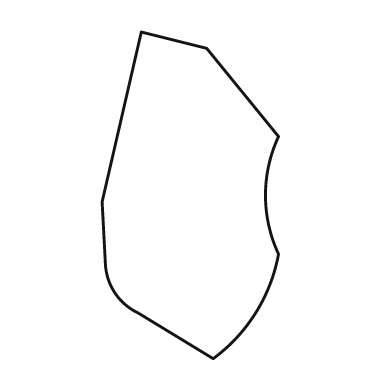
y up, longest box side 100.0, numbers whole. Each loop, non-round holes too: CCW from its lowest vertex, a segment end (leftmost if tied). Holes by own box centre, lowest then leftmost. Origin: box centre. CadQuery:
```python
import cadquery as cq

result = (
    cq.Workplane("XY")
    .moveTo(7.0, -50.0)
    .threePointArc((20.0, -36.0), (27.0, -18.0))
    .threePointArc((23.0, 0.0), (27.0, 18.0))
    .lineTo(5.0, 45.0)
    .lineTo(-15.0, 50.0)
    .lineTo(-27.0, -2.0)
    .lineTo(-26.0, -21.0)
    .threePointArc((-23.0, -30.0), (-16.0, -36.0))
    .close()
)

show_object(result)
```